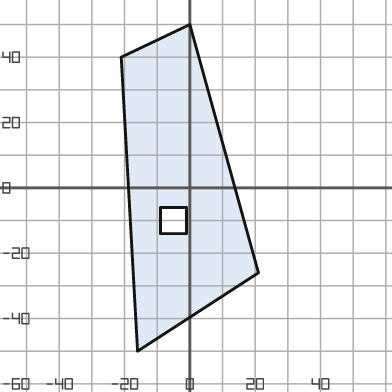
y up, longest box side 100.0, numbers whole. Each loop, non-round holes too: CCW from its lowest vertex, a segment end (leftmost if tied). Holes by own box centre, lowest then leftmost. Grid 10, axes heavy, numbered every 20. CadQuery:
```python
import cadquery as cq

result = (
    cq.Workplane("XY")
    .moveTo(-16.0, -50.0)
    .lineTo(21.0, -26.0)
    .lineTo(0.0, 50.0)
    .lineTo(-21.0, 40.0)
    .close()
    .moveTo(-9.0, -14.0)
    .lineTo(-1.0, -14.0)
    .lineTo(-1.0, -6.0)
    .lineTo(-9.0, -6.0)
    .close()
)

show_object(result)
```